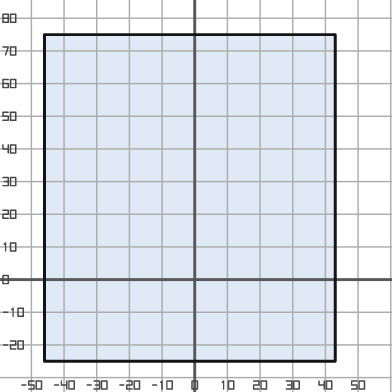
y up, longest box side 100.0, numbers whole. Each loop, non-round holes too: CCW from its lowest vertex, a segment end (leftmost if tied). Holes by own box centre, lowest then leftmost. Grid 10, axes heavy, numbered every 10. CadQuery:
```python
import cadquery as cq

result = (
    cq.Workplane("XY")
    .moveTo(-46.0, -25.0)
    .lineTo(43.0, -25.0)
    .lineTo(43.0, 75.0)
    .lineTo(-46.0, 75.0)
    .close()
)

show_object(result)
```